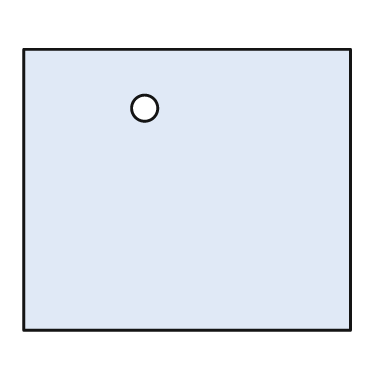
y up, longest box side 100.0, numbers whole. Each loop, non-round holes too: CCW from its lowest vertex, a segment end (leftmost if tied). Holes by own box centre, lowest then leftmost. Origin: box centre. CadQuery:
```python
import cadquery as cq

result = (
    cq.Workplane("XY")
    .moveTo(-50.0, -43.0)
    .lineTo(50.0, -43.0)
    .lineTo(50.0, 43.0)
    .lineTo(-50.0, 43.0)
    .close()
    .moveTo(-13.0, 25.0)
    .circle(4.0)
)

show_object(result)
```